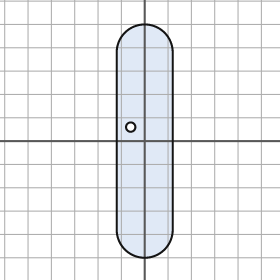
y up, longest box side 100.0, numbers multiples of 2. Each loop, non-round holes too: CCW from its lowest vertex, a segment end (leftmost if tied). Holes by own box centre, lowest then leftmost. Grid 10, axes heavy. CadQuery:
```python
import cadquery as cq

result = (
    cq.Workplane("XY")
    .moveTo(-12.0, -38.0)
    .threePointArc((0.0, -50.0), (12.0, -38.0))
    .lineTo(12.0, 38.0)
    .threePointArc((0.0, 50.0), (-12.0, 38.0))
    .close()
    .moveTo(-6.0, 6.0)
    .circle(2.0)
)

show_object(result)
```